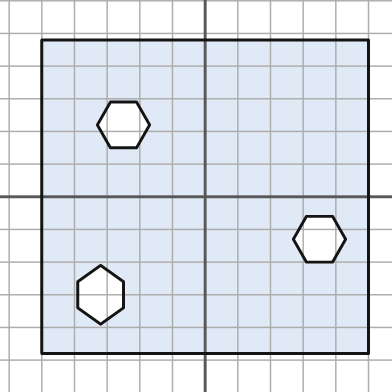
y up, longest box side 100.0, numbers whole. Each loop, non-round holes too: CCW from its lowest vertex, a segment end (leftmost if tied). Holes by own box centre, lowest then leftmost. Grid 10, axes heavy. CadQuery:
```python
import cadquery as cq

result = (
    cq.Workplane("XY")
    .moveTo(-50.0, -48.0)
    .lineTo(50.0, -48.0)
    .lineTo(50.0, 48.0)
    .lineTo(-50.0, 48.0)
    .close()
    .moveTo(-32.0, -39.0)
    .lineTo(-25.0, -34.0)
    .lineTo(-25.0, -26.0)
    .lineTo(-32.0, -21.0)
    .lineTo(-39.0, -26.0)
    .lineTo(-39.0, -34.0)
    .close()
    .moveTo(31.0, -20.0)
    .lineTo(39.0, -20.0)
    .lineTo(43.0, -13.0)
    .lineTo(39.0, -6.0)
    .lineTo(31.0, -6.0)
    .lineTo(27.0, -13.0)
    .close()
    .moveTo(-29.0, 15.0)
    .lineTo(-21.0, 15.0)
    .lineTo(-17.0, 22.0)
    .lineTo(-21.0, 29.0)
    .lineTo(-29.0, 29.0)
    .lineTo(-33.0, 22.0)
    .close()
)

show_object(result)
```